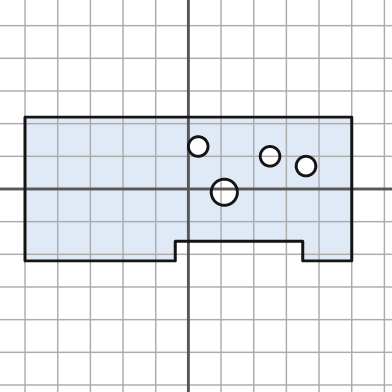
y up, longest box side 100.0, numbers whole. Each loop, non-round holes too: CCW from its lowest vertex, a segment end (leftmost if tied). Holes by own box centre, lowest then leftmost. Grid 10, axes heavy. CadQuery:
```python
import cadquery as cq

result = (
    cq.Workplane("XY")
    .moveTo(-50.0, -22.0)
    .lineTo(-4.0, -22.0)
    .lineTo(-4.0, -16.0)
    .lineTo(35.0, -16.0)
    .lineTo(35.0, -22.0)
    .lineTo(50.0, -22.0)
    .lineTo(50.0, 22.0)
    .lineTo(-50.0, 22.0)
    .close()
    .moveTo(11.0, -1.0)
    .circle(4.0)
    .moveTo(36.0, 7.0)
    .circle(3.0)
    .moveTo(25.0, 10.0)
    .circle(3.0)
    .moveTo(3.0, 13.0)
    .circle(3.0)
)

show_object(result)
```